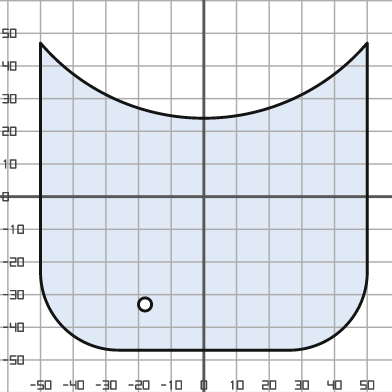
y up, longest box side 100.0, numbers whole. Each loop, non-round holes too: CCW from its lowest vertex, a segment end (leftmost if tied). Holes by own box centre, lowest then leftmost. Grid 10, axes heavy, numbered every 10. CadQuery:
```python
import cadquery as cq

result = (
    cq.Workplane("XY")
    .moveTo(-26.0, -47.0)
    .lineTo(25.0, -47.0)
    .threePointArc((43.0, -40.0), (50.0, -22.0))
    .lineTo(50.0, 47.0)
    .threePointArc((0.0, 24.0), (-50.0, 47.0))
    .lineTo(-50.0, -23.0)
    .threePointArc((-43.0, -40.0), (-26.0, -47.0))
    .close()
    .moveTo(-18.0, -33.0)
    .circle(2.0)
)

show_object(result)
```